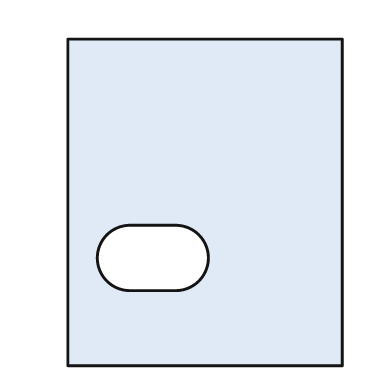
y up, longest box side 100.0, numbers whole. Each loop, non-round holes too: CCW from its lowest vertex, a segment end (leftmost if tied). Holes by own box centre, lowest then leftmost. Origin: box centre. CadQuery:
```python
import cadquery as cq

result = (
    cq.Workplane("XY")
    .moveTo(-42.0, -50.0)
    .lineTo(42.0, -50.0)
    .lineTo(42.0, 50.0)
    .lineTo(-42.0, 50.0)
    .close()
    .moveTo(-23.0, -27.0)
    .lineTo(-9.0, -27.0)
    .threePointArc((1.0, -17.0), (-9.0, -7.0))
    .lineTo(-23.0, -7.0)
    .threePointArc((-33.0, -17.0), (-23.0, -27.0))
    .close()
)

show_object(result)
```